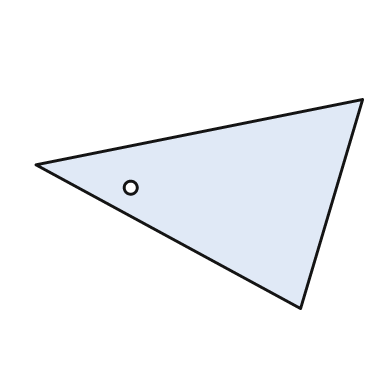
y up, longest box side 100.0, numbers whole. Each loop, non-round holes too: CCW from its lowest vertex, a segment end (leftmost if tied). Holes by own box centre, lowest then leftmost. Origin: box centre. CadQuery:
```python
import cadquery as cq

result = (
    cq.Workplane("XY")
    .moveTo(31.0, -32.0)
    .lineTo(50.0, 32.0)
    .lineTo(-50.0, 12.0)
    .close()
    .moveTo(-21.0, 5.0)
    .circle(2.0)
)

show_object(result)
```